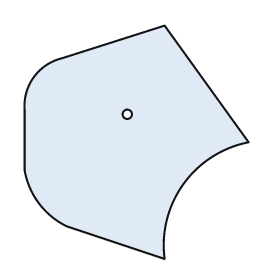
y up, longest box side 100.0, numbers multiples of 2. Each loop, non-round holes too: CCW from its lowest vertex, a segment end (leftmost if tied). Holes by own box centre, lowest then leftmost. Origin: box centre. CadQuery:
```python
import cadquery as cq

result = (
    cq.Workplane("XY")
    .moveTo(12.0, -50.0)
    .threePointArc((20.0, -18.0), (48.0, 0.0))
    .lineTo(12.0, 50.0)
    .lineTo(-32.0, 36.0)
    .threePointArc((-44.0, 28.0), (-48.0, 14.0))
    .lineTo(-48.0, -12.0)
    .threePointArc((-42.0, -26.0), (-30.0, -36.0))
    .close()
    .moveTo(-4.0, 12.0)
    .circle(2.0)
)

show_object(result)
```